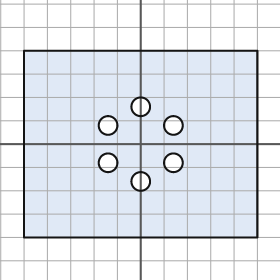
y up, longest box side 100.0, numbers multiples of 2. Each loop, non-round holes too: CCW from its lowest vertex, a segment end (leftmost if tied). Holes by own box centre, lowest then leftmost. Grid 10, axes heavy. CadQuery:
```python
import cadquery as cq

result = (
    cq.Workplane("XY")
    .moveTo(-50.0, -40.0)
    .lineTo(50.0, -40.0)
    .lineTo(50.0, 40.0)
    .lineTo(-50.0, 40.0)
    .close()
    .moveTo(0.0, -16.0)
    .circle(4.0)
    .moveTo(-14.0, -8.0)
    .circle(4.0)
    .moveTo(14.0, -8.0)
    .circle(4.0)
    .moveTo(-14.0, 8.0)
    .circle(4.0)
    .moveTo(14.0, 8.0)
    .circle(4.0)
    .moveTo(0.0, 16.0)
    .circle(4.0)
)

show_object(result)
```